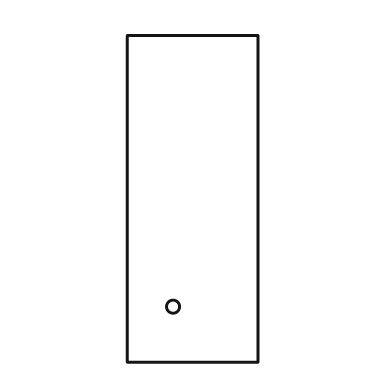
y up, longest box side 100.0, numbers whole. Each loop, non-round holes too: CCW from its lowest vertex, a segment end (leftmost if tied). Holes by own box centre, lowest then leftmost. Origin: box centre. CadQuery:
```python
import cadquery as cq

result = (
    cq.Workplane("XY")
    .moveTo(-20.0, -50.0)
    .lineTo(20.0, -50.0)
    .lineTo(20.0, 50.0)
    .lineTo(-20.0, 50.0)
    .close()
    .moveTo(-6.0, -33.0)
    .circle(2.0)
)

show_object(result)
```